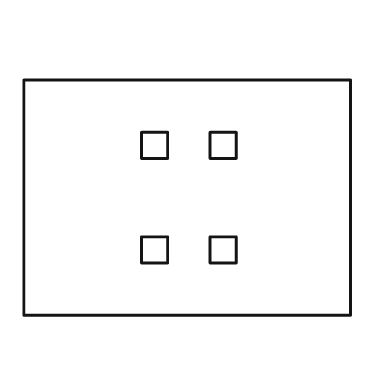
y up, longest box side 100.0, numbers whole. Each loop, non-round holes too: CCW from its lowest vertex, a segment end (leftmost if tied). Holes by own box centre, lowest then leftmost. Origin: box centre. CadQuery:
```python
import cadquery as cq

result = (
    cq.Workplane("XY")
    .moveTo(-50.0, -36.0)
    .lineTo(50.0, -36.0)
    .lineTo(50.0, 36.0)
    .lineTo(-50.0, 36.0)
    .close()
    .moveTo(-14.0, -20.0)
    .lineTo(-6.0, -20.0)
    .lineTo(-6.0, -12.0)
    .lineTo(-14.0, -12.0)
    .close()
    .moveTo(7.0, -20.0)
    .lineTo(15.0, -20.0)
    .lineTo(15.0, -12.0)
    .lineTo(7.0, -12.0)
    .close()
    .moveTo(-14.0, 12.0)
    .lineTo(-6.0, 12.0)
    .lineTo(-6.0, 20.0)
    .lineTo(-14.0, 20.0)
    .close()
    .moveTo(7.0, 12.0)
    .lineTo(15.0, 12.0)
    .lineTo(15.0, 20.0)
    .lineTo(7.0, 20.0)
    .close()
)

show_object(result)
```